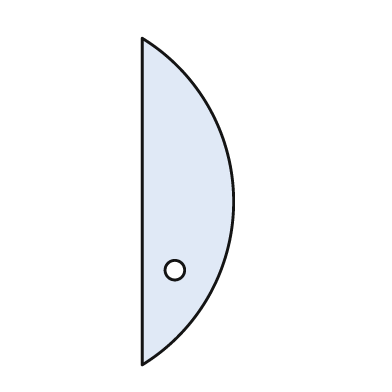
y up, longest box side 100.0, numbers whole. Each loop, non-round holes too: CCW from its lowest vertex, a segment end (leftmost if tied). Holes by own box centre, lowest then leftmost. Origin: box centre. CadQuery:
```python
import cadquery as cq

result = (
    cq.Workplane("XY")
    .moveTo(-14.0, -50.0)
    .threePointArc((14.0, 0.0), (-14.0, 50.0))
    .close()
    .moveTo(-4.0, -21.0)
    .circle(3.0)
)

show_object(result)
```